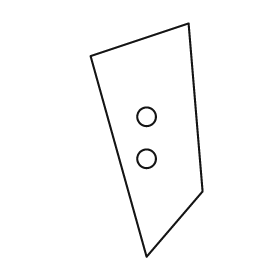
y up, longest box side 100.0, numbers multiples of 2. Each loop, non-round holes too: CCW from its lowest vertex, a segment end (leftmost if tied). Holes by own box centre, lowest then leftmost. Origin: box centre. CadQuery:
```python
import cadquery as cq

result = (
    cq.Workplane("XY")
    .moveTo(0.0, -50.0)
    .lineTo(24.0, -22.0)
    .lineTo(18.0, 50.0)
    .lineTo(-24.0, 36.0)
    .close()
    .moveTo(0.0, -8.0)
    .circle(4.0)
    .moveTo(0.0, 10.0)
    .circle(4.0)
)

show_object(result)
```